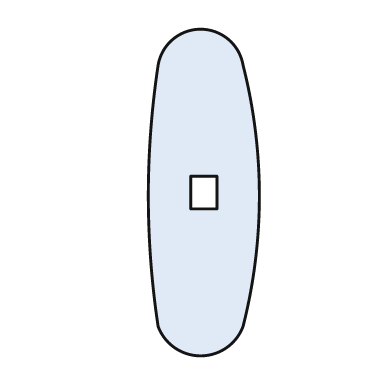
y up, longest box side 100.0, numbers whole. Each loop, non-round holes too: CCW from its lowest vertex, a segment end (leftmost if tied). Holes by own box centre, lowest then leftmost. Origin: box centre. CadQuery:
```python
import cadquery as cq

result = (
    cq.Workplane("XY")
    .moveTo(-14.0, -41.0)
    .threePointArc((-1.0, -50.0), (12.0, -41.0))
    .threePointArc((17.0, -1.0), (12.0, 39.0))
    .threePointArc((-1.0, 50.0), (-14.0, 39.0))
    .threePointArc((-17.0, -1.0), (-14.0, -41.0))
    .close()
    .moveTo(-4.0, -5.0)
    .lineTo(4.0, -5.0)
    .lineTo(4.0, 5.0)
    .lineTo(-4.0, 5.0)
    .close()
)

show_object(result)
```